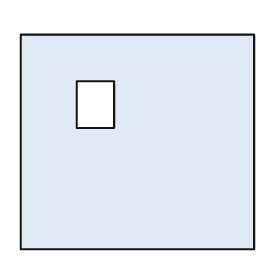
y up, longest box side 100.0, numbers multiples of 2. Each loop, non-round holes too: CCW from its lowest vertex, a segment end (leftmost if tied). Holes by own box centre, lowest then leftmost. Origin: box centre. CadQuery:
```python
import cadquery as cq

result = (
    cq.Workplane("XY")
    .moveTo(-50.0, -46.0)
    .lineTo(50.0, -46.0)
    .lineTo(50.0, 46.0)
    .lineTo(-50.0, 46.0)
    .close()
    .moveTo(-26.0, 6.0)
    .lineTo(-10.0, 6.0)
    .lineTo(-10.0, 26.0)
    .lineTo(-26.0, 26.0)
    .close()
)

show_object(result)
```